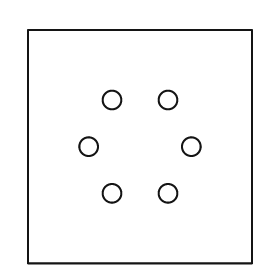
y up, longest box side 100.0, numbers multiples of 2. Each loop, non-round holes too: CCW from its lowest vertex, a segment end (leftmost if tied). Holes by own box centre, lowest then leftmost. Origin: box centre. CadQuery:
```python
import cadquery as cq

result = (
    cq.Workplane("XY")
    .moveTo(-48.0, -50.0)
    .lineTo(48.0, -50.0)
    .lineTo(48.0, 50.0)
    .lineTo(-48.0, 50.0)
    .close()
    .moveTo(-12.0, -20.0)
    .circle(4.0)
    .moveTo(12.0, -20.0)
    .circle(4.0)
    .moveTo(-22.0, 0.0)
    .circle(4.0)
    .moveTo(22.0, 0.0)
    .circle(4.0)
    .moveTo(-12.0, 20.0)
    .circle(4.0)
    .moveTo(12.0, 20.0)
    .circle(4.0)
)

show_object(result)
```